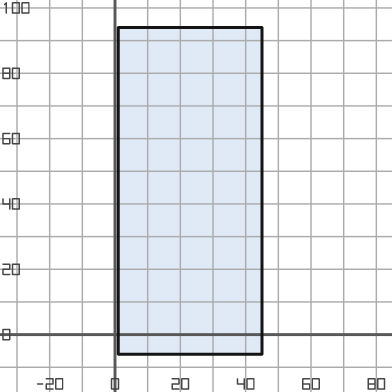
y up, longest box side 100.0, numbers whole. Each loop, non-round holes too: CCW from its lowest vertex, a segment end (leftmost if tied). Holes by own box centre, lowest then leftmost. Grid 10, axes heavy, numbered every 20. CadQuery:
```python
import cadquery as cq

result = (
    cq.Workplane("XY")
    .moveTo(1.0, -6.0)
    .lineTo(45.0, -6.0)
    .lineTo(45.0, 94.0)
    .lineTo(1.0, 94.0)
    .close()
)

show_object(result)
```